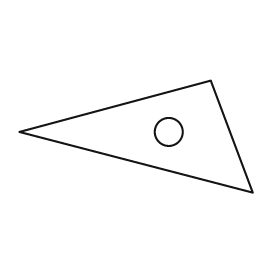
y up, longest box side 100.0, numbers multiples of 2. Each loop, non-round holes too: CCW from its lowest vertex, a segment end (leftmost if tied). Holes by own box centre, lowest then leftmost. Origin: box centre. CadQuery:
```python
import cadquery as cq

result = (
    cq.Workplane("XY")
    .moveTo(50.0, -24.0)
    .lineTo(32.0, 24.0)
    .lineTo(-50.0, 2.0)
    .close()
    .moveTo(14.0, 2.0)
    .circle(6.0)
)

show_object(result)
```